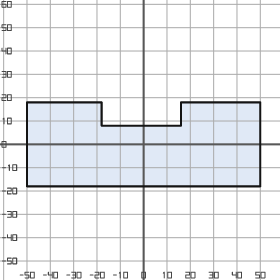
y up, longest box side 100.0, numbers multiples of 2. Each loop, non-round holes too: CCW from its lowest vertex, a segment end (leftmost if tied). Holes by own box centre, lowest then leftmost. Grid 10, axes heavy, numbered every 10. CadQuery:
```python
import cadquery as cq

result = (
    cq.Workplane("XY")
    .moveTo(-50.0, -18.0)
    .lineTo(50.0, -18.0)
    .lineTo(50.0, 18.0)
    .lineTo(16.0, 18.0)
    .lineTo(16.0, 8.0)
    .lineTo(-18.0, 8.0)
    .lineTo(-18.0, 18.0)
    .lineTo(-50.0, 18.0)
    .close()
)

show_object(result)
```